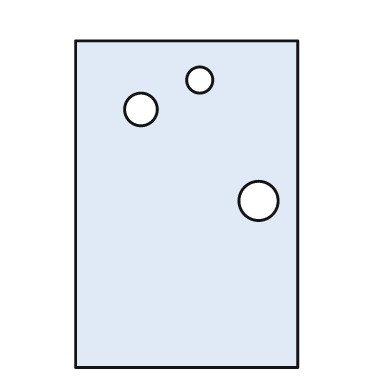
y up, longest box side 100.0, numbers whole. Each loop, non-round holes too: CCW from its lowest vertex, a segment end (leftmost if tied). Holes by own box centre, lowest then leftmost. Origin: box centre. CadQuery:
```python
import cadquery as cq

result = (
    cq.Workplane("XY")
    .moveTo(-34.0, -50.0)
    .lineTo(34.0, -50.0)
    .lineTo(34.0, 50.0)
    .lineTo(-34.0, 50.0)
    .close()
    .moveTo(22.0, 1.0)
    .circle(6.0)
    .moveTo(-14.0, 29.0)
    .circle(5.0)
    .moveTo(4.0, 38.0)
    .circle(4.0)
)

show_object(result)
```